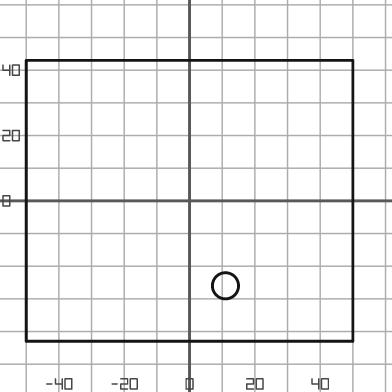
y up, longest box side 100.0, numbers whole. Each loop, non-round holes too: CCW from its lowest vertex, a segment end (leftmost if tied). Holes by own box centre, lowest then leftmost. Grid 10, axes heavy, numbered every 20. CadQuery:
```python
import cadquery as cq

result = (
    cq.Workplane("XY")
    .moveTo(-50.0, -43.0)
    .lineTo(50.0, -43.0)
    .lineTo(50.0, 43.0)
    .lineTo(-50.0, 43.0)
    .close()
    .moveTo(11.0, -26.0)
    .circle(4.0)
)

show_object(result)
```